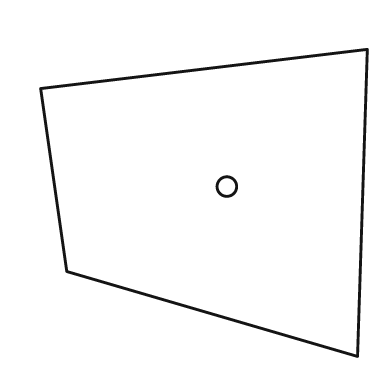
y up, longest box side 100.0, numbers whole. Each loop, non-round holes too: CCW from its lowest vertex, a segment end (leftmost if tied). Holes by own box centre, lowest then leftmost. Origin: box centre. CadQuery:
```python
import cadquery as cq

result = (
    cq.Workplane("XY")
    .moveTo(47.0, -47.0)
    .lineTo(50.0, 47.0)
    .lineTo(-50.0, 35.0)
    .lineTo(-42.0, -21.0)
    .close()
    .moveTo(7.0, 5.0)
    .circle(3.0)
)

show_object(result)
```